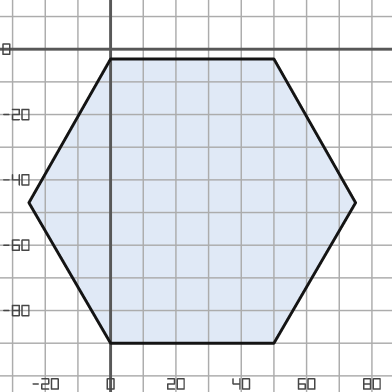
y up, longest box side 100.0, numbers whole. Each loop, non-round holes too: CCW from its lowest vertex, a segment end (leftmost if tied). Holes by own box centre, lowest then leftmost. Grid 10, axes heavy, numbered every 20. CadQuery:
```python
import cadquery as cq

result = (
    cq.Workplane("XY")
    .moveTo(0.0, -90.0)
    .lineTo(50.0, -90.0)
    .lineTo(75.0, -47.0)
    .lineTo(50.0, -3.0)
    .lineTo(0.0, -3.0)
    .lineTo(-25.0, -47.0)
    .close()
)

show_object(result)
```